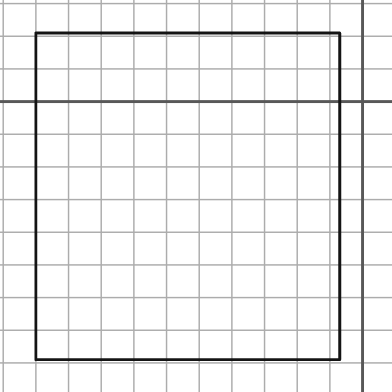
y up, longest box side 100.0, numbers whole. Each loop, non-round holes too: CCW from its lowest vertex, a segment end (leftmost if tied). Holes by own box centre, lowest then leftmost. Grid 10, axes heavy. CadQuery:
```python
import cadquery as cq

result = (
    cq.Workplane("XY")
    .moveTo(-100.0, -79.0)
    .lineTo(-7.0, -79.0)
    .lineTo(-7.0, 21.0)
    .lineTo(-100.0, 21.0)
    .close()
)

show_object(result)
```